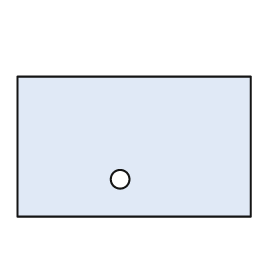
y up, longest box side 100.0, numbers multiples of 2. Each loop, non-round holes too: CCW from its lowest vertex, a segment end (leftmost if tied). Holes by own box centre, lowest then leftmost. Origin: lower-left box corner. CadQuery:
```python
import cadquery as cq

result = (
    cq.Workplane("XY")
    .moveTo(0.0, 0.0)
    .lineTo(100.0, 0.0)
    .lineTo(100.0, 60.0)
    .lineTo(0.0, 60.0)
    .close()
    .moveTo(44.0, 16.0)
    .circle(4.0)
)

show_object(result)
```